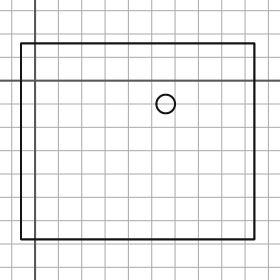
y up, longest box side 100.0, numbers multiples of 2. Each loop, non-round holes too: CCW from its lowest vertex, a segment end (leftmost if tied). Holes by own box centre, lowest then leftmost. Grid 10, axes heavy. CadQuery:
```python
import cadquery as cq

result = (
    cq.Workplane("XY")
    .moveTo(-6.0, -68.0)
    .lineTo(94.0, -68.0)
    .lineTo(94.0, 16.0)
    .lineTo(-6.0, 16.0)
    .close()
    .moveTo(56.0, -10.0)
    .circle(4.0)
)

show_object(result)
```